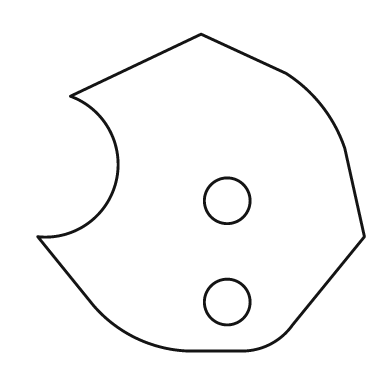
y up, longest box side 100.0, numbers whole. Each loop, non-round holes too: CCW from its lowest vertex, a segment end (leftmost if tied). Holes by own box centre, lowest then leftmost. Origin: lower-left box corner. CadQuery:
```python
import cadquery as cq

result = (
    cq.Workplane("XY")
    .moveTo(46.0, 0.0)
    .lineTo(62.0, 0.0)
    .threePointArc((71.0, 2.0), (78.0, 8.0))
    .lineTo(100.0, 35.0)
    .lineTo(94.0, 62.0)
    .threePointArc((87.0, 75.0), (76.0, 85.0))
    .lineTo(50.0, 97.0)
    .lineTo(10.0, 78.0)
    .threePointArc((24.0, 52.0), (0.0, 35.0))
    .lineTo(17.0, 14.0)
    .threePointArc((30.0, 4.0), (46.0, 0.0))
    .close()
    .moveTo(58.0, 15.0)
    .circle(7.0)
    .moveTo(58.0, 46.0)
    .circle(7.0)
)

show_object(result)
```